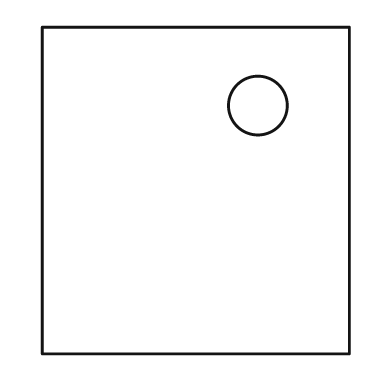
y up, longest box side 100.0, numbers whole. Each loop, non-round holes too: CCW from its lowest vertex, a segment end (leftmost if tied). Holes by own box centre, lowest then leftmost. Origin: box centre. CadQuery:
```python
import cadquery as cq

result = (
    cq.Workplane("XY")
    .moveTo(-47.0, -50.0)
    .lineTo(47.0, -50.0)
    .lineTo(47.0, 50.0)
    .lineTo(-47.0, 50.0)
    .close()
    .moveTo(19.0, 26.0)
    .circle(9.0)
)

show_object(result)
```